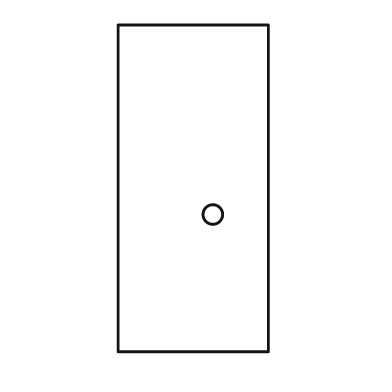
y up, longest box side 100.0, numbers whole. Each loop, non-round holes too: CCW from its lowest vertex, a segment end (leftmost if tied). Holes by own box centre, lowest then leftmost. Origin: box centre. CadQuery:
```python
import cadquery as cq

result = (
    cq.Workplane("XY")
    .moveTo(-23.0, -50.0)
    .lineTo(23.0, -50.0)
    .lineTo(23.0, 50.0)
    .lineTo(-23.0, 50.0)
    .close()
    .moveTo(6.0, -8.0)
    .circle(3.0)
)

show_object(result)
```